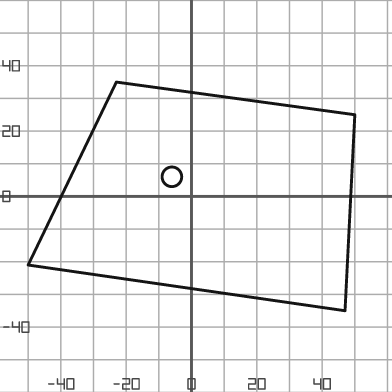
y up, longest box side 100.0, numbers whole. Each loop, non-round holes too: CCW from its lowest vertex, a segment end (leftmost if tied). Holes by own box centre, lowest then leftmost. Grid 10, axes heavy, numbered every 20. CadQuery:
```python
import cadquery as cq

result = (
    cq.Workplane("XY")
    .moveTo(47.0, -35.0)
    .lineTo(50.0, 25.0)
    .lineTo(-23.0, 35.0)
    .lineTo(-50.0, -21.0)
    .close()
    .moveTo(-6.0, 6.0)
    .circle(3.0)
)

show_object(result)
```